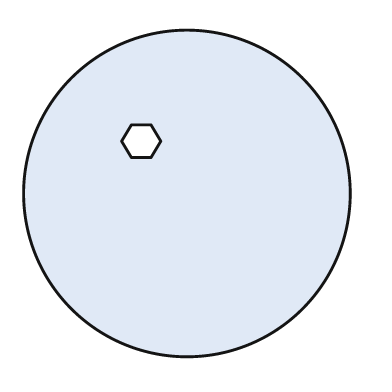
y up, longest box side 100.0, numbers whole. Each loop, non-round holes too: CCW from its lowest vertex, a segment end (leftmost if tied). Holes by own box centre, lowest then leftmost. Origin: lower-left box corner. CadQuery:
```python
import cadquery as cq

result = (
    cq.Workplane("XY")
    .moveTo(50.0, 50.0)
    .circle(50.0)
    .moveTo(33.0, 61.0)
    .lineTo(39.0, 61.0)
    .lineTo(42.0, 66.0)
    .lineTo(39.0, 71.0)
    .lineTo(33.0, 71.0)
    .lineTo(30.0, 66.0)
    .close()
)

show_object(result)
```